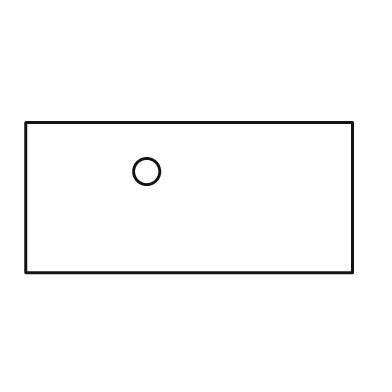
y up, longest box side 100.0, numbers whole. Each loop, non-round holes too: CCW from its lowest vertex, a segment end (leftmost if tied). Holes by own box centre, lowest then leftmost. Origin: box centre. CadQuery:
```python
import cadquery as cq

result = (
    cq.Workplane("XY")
    .moveTo(-50.0, -23.0)
    .lineTo(50.0, -23.0)
    .lineTo(50.0, 23.0)
    .lineTo(-50.0, 23.0)
    .close()
    .moveTo(-13.0, 8.0)
    .circle(4.0)
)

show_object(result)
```